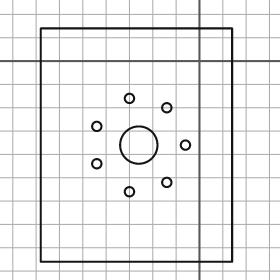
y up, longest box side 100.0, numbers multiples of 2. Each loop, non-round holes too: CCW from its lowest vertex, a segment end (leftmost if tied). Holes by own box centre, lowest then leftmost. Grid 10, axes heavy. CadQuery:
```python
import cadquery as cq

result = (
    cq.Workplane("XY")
    .moveTo(-68.0, -86.0)
    .lineTo(14.0, -86.0)
    .lineTo(14.0, 14.0)
    .lineTo(-68.0, 14.0)
    .close()
    .moveTo(-30.0, -56.0)
    .circle(2.0)
    .moveTo(-14.0, -52.0)
    .circle(2.0)
    .moveTo(-44.0, -44.0)
    .circle(2.0)
    .moveTo(-26.0, -36.0)
    .circle(8.0)
    .moveTo(-6.0, -36.0)
    .circle(2.0)
    .moveTo(-44.0, -28.0)
    .circle(2.0)
    .moveTo(-14.0, -20.0)
    .circle(2.0)
    .moveTo(-30.0, -16.0)
    .circle(2.0)
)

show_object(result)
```